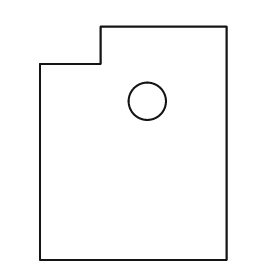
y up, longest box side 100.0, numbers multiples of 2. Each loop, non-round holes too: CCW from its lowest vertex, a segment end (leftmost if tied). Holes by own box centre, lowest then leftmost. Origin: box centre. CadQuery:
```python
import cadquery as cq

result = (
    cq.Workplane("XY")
    .moveTo(-40.0, -50.0)
    .lineTo(40.0, -50.0)
    .lineTo(40.0, 50.0)
    .lineTo(-14.0, 50.0)
    .lineTo(-14.0, 34.0)
    .lineTo(-40.0, 34.0)
    .close()
    .moveTo(6.0, 18.0)
    .circle(8.0)
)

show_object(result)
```